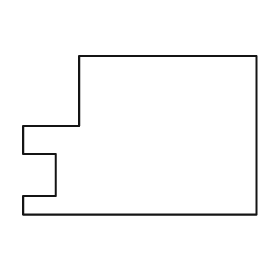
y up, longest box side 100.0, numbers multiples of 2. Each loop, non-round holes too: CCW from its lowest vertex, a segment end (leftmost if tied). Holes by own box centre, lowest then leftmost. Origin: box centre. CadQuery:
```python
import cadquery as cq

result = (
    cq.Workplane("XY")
    .moveTo(-50.0, -34.0)
    .lineTo(50.0, -34.0)
    .lineTo(50.0, 34.0)
    .lineTo(-26.0, 34.0)
    .lineTo(-26.0, 4.0)
    .lineTo(-50.0, 4.0)
    .lineTo(-50.0, -8.0)
    .lineTo(-36.0, -8.0)
    .lineTo(-36.0, -26.0)
    .lineTo(-50.0, -26.0)
    .close()
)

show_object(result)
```